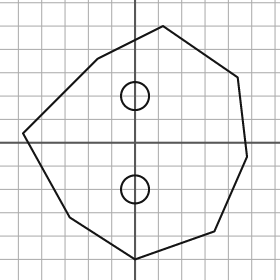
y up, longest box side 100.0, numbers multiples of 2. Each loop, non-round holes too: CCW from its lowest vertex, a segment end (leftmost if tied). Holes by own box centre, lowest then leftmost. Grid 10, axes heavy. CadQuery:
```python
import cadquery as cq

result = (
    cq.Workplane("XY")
    .moveTo(0.0, -50.0)
    .lineTo(34.0, -38.0)
    .lineTo(48.0, -6.0)
    .lineTo(44.0, 28.0)
    .lineTo(12.0, 50.0)
    .lineTo(-16.0, 36.0)
    .lineTo(-48.0, 4.0)
    .lineTo(-28.0, -32.0)
    .close()
    .moveTo(0.0, -20.0)
    .circle(6.0)
    .moveTo(0.0, 20.0)
    .circle(6.0)
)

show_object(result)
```